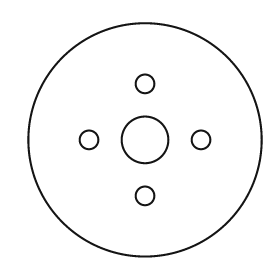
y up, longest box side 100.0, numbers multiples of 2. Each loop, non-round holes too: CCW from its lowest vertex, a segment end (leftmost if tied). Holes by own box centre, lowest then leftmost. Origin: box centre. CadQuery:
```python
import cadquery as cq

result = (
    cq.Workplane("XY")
    .moveTo(0.0, 0.0)
    .circle(50.0)
    .moveTo(0.0, -24.0)
    .circle(4.0)
    .moveTo(-24.0, 0.0)
    .circle(4.0)
    .moveTo(0.0, 0.0)
    .circle(10.0)
    .moveTo(24.0, 0.0)
    .circle(4.0)
    .moveTo(0.0, 24.0)
    .circle(4.0)
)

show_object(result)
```